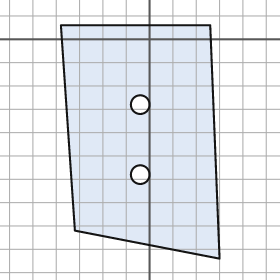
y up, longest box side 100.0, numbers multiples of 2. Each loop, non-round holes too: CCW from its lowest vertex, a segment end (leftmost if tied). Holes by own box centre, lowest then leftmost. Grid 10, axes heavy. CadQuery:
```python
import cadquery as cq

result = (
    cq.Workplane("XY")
    .moveTo(30.0, -94.0)
    .lineTo(26.0, 6.0)
    .lineTo(-38.0, 6.0)
    .lineTo(-32.0, -82.0)
    .close()
    .moveTo(-4.0, -58.0)
    .circle(4.0)
    .moveTo(-4.0, -28.0)
    .circle(4.0)
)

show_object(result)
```